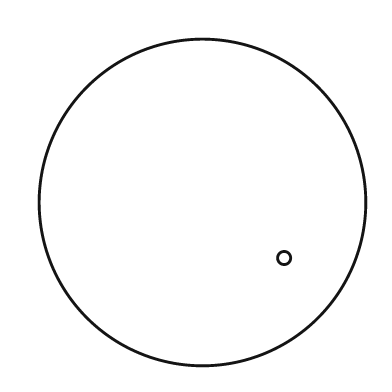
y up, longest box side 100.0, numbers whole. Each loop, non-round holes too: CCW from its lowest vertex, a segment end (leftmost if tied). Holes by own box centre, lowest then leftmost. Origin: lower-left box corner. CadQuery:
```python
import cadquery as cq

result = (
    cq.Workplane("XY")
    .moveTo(50.0, 50.0)
    .circle(50.0)
    .moveTo(75.0, 33.0)
    .circle(2.0)
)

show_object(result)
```